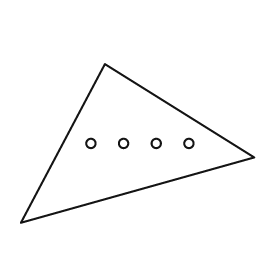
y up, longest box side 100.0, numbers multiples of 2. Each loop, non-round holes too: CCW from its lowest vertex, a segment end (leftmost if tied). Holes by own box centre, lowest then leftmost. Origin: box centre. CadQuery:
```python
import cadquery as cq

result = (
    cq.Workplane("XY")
    .moveTo(-50.0, -34.0)
    .lineTo(50.0, -6.0)
    .lineTo(-14.0, 34.0)
    .close()
    .moveTo(-20.0, 0.0)
    .circle(2.0)
    .moveTo(-6.0, 0.0)
    .circle(2.0)
    .moveTo(8.0, 0.0)
    .circle(2.0)
    .moveTo(22.0, 0.0)
    .circle(2.0)
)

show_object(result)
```